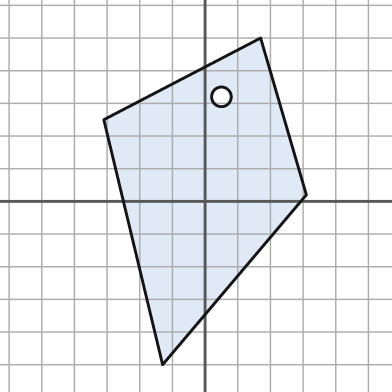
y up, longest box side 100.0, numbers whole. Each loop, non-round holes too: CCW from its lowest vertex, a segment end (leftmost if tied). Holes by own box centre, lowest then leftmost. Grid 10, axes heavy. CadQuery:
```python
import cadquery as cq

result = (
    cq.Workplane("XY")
    .moveTo(-13.0, -50.0)
    .lineTo(31.0, 2.0)
    .lineTo(17.0, 50.0)
    .lineTo(-31.0, 25.0)
    .close()
    .moveTo(5.0, 32.0)
    .circle(3.0)
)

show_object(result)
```